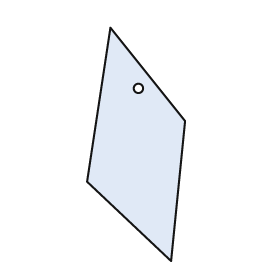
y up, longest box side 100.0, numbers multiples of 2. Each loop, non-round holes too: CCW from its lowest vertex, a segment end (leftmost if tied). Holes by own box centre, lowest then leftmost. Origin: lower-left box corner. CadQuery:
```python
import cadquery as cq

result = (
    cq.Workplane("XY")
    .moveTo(36.0, 0.0)
    .lineTo(42.0, 60.0)
    .lineTo(10.0, 100.0)
    .lineTo(0.0, 34.0)
    .close()
    .moveTo(22.0, 74.0)
    .circle(2.0)
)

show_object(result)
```